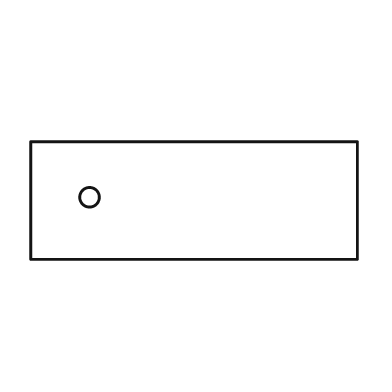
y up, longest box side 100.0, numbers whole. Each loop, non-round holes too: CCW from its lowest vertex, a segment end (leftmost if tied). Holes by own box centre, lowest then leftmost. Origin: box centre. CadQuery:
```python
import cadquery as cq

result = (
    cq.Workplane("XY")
    .moveTo(-50.0, -18.0)
    .lineTo(50.0, -18.0)
    .lineTo(50.0, 18.0)
    .lineTo(-50.0, 18.0)
    .close()
    .moveTo(-32.0, 1.0)
    .circle(3.0)
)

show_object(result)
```